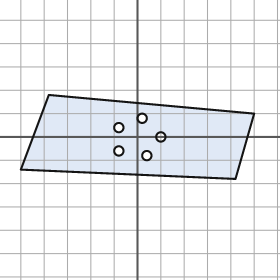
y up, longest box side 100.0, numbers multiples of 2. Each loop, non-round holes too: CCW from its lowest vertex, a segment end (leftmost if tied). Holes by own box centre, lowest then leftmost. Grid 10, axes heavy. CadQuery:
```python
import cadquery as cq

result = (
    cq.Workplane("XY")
    .moveTo(42.0, -18.0)
    .lineTo(50.0, 10.0)
    .lineTo(-38.0, 18.0)
    .lineTo(-50.0, -14.0)
    .close()
    .moveTo(4.0, -8.0)
    .circle(2.0)
    .moveTo(-8.0, -6.0)
    .circle(2.0)
    .moveTo(10.0, 0.0)
    .circle(2.0)
    .moveTo(-8.0, 4.0)
    .circle(2.0)
    .moveTo(2.0, 8.0)
    .circle(2.0)
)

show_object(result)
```